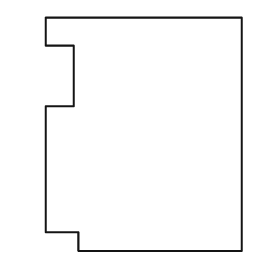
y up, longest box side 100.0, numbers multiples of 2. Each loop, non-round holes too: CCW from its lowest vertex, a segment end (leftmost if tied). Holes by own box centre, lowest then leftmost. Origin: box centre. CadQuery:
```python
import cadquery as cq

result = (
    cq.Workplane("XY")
    .moveTo(-28.0, -50.0)
    .lineTo(42.0, -50.0)
    .lineTo(42.0, 50.0)
    .lineTo(-42.0, 50.0)
    .lineTo(-42.0, 38.0)
    .lineTo(-30.0, 38.0)
    .lineTo(-30.0, 12.0)
    .lineTo(-42.0, 12.0)
    .lineTo(-42.0, -42.0)
    .lineTo(-28.0, -42.0)
    .close()
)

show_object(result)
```